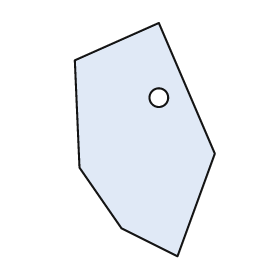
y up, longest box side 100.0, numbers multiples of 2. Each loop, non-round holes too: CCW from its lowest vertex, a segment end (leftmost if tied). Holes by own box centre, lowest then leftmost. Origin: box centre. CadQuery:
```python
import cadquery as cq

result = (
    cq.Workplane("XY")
    .moveTo(14.0, -50.0)
    .lineTo(30.0, -6.0)
    .lineTo(6.0, 50.0)
    .lineTo(-30.0, 34.0)
    .lineTo(-28.0, -12.0)
    .lineTo(-10.0, -38.0)
    .close()
    .moveTo(6.0, 18.0)
    .circle(4.0)
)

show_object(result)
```